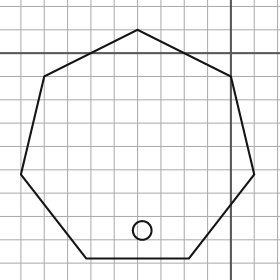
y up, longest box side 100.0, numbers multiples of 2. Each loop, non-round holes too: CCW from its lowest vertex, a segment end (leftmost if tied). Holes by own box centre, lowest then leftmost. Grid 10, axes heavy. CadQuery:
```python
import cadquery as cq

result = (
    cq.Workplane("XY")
    .moveTo(-62.0, -88.0)
    .lineTo(-18.0, -88.0)
    .lineTo(10.0, -52.0)
    .lineTo(0.0, -10.0)
    .lineTo(-40.0, 10.0)
    .lineTo(-80.0, -10.0)
    .lineTo(-90.0, -52.0)
    .close()
    .moveTo(-38.0, -76.0)
    .circle(4.0)
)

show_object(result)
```